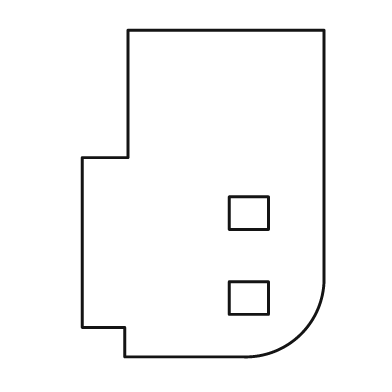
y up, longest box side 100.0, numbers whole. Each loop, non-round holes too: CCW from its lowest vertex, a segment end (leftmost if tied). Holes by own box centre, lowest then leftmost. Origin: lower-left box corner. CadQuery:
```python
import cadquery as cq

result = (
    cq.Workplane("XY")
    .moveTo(13.0, 0.0)
    .lineTo(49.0, 0.0)
    .threePointArc((67.0, 7.0), (74.0, 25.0))
    .lineTo(74.0, 100.0)
    .lineTo(14.0, 100.0)
    .lineTo(14.0, 61.0)
    .lineTo(0.0, 61.0)
    .lineTo(0.0, 9.0)
    .lineTo(13.0, 9.0)
    .close()
    .moveTo(45.0, 13.0)
    .lineTo(57.0, 13.0)
    .lineTo(57.0, 23.0)
    .lineTo(45.0, 23.0)
    .close()
    .moveTo(45.0, 39.0)
    .lineTo(57.0, 39.0)
    .lineTo(57.0, 49.0)
    .lineTo(45.0, 49.0)
    .close()
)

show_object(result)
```